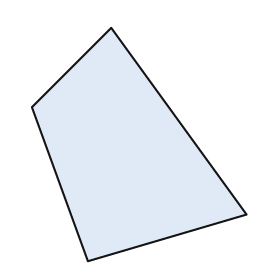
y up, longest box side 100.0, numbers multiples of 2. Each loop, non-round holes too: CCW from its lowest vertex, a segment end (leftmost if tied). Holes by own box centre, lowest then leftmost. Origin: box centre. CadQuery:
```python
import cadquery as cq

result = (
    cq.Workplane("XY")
    .moveTo(-22.0, -50.0)
    .lineTo(46.0, -30.0)
    .lineTo(-12.0, 50.0)
    .lineTo(-46.0, 16.0)
    .close()
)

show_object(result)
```